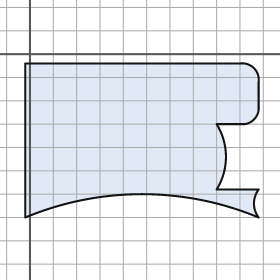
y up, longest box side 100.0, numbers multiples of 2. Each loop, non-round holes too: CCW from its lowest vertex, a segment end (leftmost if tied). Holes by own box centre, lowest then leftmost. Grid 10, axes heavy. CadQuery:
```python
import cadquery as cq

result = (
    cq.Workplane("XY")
    .moveTo(-2.0, -70.0)
    .threePointArc((48.0, -60.0), (98.0, -70.0))
    .threePointArc((96.0, -64.0), (98.0, -58.0))
    .lineTo(80.0, -58.0)
    .threePointArc((84.0, -44.0), (80.0, -30.0))
    .lineTo(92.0, -30.0)
    .threePointArc((96.0, -28.0), (98.0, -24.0))
    .lineTo(98.0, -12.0)
    .threePointArc((96.0, -6.0), (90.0, -4.0))
    .lineTo(-2.0, -4.0)
    .close()
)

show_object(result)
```